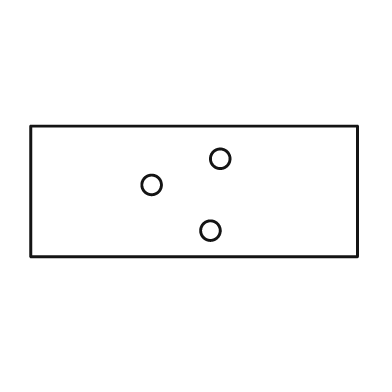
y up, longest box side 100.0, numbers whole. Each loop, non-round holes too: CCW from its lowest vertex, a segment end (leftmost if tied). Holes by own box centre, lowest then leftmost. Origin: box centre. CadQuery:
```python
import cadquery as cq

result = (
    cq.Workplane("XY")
    .moveTo(-50.0, -20.0)
    .lineTo(50.0, -20.0)
    .lineTo(50.0, 20.0)
    .lineTo(-50.0, 20.0)
    .close()
    .moveTo(5.0, -12.0)
    .circle(3.0)
    .moveTo(-13.0, 2.0)
    .circle(3.0)
    .moveTo(8.0, 10.0)
    .circle(3.0)
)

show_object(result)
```